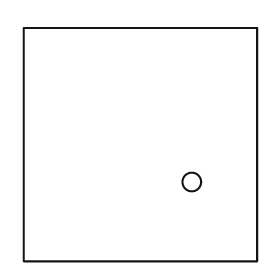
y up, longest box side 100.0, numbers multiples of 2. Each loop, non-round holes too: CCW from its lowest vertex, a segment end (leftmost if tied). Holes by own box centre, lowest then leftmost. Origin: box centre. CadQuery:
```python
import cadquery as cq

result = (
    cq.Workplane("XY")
    .moveTo(-50.0, -50.0)
    .lineTo(50.0, -50.0)
    .lineTo(50.0, 50.0)
    .lineTo(-50.0, 50.0)
    .close()
    .moveTo(22.0, -16.0)
    .circle(4.0)
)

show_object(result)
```